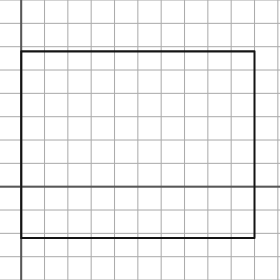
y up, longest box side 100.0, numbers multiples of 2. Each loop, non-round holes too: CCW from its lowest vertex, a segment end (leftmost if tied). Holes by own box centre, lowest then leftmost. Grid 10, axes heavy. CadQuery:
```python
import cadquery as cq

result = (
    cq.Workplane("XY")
    .moveTo(0.0, -22.0)
    .lineTo(100.0, -22.0)
    .lineTo(100.0, 58.0)
    .lineTo(0.0, 58.0)
    .close()
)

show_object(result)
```